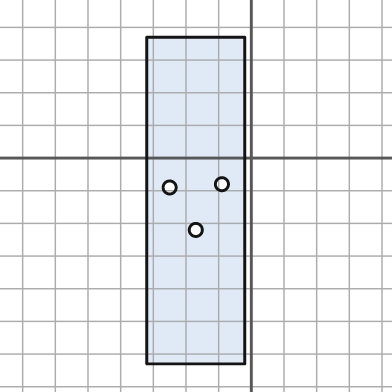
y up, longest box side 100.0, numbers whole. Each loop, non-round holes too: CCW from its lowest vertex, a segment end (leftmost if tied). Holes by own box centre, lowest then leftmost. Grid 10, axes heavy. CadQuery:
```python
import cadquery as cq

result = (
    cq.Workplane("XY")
    .moveTo(-32.0, -63.0)
    .lineTo(-2.0, -63.0)
    .lineTo(-2.0, 37.0)
    .lineTo(-32.0, 37.0)
    .close()
    .moveTo(-17.0, -22.0)
    .circle(2.0)
    .moveTo(-25.0, -9.0)
    .circle(2.0)
    .moveTo(-9.0, -8.0)
    .circle(2.0)
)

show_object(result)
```